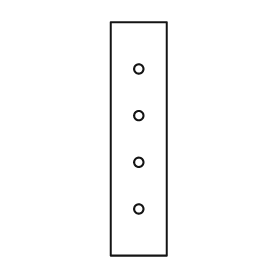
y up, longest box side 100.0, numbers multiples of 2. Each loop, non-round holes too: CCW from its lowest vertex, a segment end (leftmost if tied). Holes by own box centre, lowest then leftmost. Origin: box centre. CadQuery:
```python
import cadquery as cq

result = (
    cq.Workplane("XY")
    .moveTo(-12.0, -50.0)
    .lineTo(12.0, -50.0)
    .lineTo(12.0, 50.0)
    .lineTo(-12.0, 50.0)
    .close()
    .moveTo(0.0, -30.0)
    .circle(2.0)
    .moveTo(0.0, -10.0)
    .circle(2.0)
    .moveTo(0.0, 10.0)
    .circle(2.0)
    .moveTo(0.0, 30.0)
    .circle(2.0)
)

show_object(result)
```